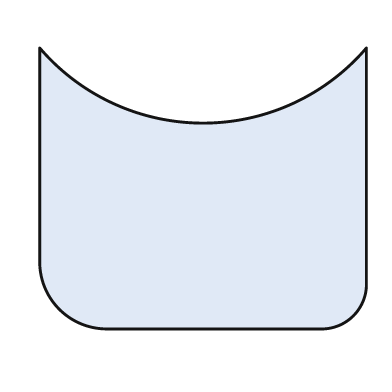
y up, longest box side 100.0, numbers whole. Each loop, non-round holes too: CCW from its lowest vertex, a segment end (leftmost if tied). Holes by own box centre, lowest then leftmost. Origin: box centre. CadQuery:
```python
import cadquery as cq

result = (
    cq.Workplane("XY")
    .moveTo(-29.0, -43.0)
    .lineTo(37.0, -43.0)
    .threePointArc((46.0, -39.0), (50.0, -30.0))
    .lineTo(50.0, 43.0)
    .threePointArc((0.0, 20.0), (-50.0, 43.0))
    .lineTo(-50.0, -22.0)
    .threePointArc((-44.0, -37.0), (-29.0, -43.0))
    .close()
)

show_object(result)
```